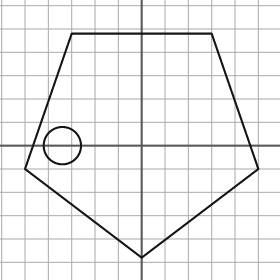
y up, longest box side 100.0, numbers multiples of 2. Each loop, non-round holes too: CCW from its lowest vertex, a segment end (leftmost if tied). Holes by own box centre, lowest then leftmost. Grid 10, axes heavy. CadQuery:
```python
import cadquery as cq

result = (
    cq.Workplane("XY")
    .moveTo(0.0, -48.0)
    .lineTo(50.0, -10.0)
    .lineTo(30.0, 48.0)
    .lineTo(-30.0, 48.0)
    .lineTo(-50.0, -10.0)
    .close()
    .moveTo(-34.0, 0.0)
    .circle(8.0)
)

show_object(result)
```